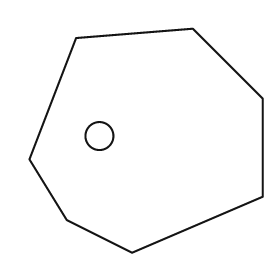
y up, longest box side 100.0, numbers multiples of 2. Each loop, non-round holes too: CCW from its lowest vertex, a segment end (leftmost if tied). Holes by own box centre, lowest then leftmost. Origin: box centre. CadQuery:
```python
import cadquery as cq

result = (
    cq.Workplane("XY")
    .moveTo(-6.0, -48.0)
    .lineTo(50.0, -24.0)
    .lineTo(50.0, 18.0)
    .lineTo(20.0, 48.0)
    .lineTo(-30.0, 44.0)
    .lineTo(-50.0, -8.0)
    .lineTo(-34.0, -34.0)
    .close()
    .moveTo(-20.0, 2.0)
    .circle(6.0)
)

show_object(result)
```